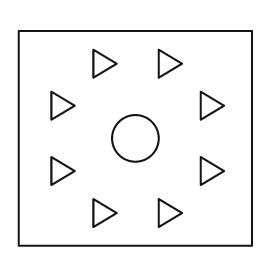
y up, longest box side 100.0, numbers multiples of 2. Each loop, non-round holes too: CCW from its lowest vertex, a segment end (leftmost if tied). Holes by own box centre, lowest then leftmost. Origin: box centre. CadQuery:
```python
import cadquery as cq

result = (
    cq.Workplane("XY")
    .moveTo(-50.0, -46.0)
    .lineTo(50.0, -46.0)
    .lineTo(50.0, 46.0)
    .lineTo(-50.0, 46.0)
    .close()
    .moveTo(-18.0, -38.0)
    .lineTo(-8.0, -32.0)
    .lineTo(-18.0, -26.0)
    .close()
    .moveTo(10.0, -38.0)
    .lineTo(20.0, -32.0)
    .lineTo(10.0, -26.0)
    .close()
    .moveTo(-36.0, -20.0)
    .lineTo(-26.0, -14.0)
    .lineTo(-36.0, -8.0)
    .close()
    .moveTo(28.0, -20.0)
    .lineTo(38.0, -14.0)
    .lineTo(28.0, -8.0)
    .close()
    .moveTo(0.0, 0.0)
    .circle(10.0)
    .moveTo(-36.0, 8.0)
    .lineTo(-26.0, 14.0)
    .lineTo(-36.0, 20.0)
    .close()
    .moveTo(28.0, 8.0)
    .lineTo(38.0, 14.0)
    .lineTo(28.0, 20.0)
    .close()
    .moveTo(-18.0, 26.0)
    .lineTo(-8.0, 32.0)
    .lineTo(-18.0, 38.0)
    .close()
    .moveTo(10.0, 26.0)
    .lineTo(20.0, 32.0)
    .lineTo(10.0, 38.0)
    .close()
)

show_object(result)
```